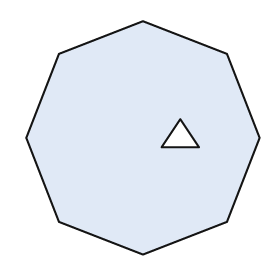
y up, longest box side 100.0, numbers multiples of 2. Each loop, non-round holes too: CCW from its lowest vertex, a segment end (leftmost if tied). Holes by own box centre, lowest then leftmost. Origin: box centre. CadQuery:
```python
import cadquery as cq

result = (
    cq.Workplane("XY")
    .moveTo(0.0, -50.0)
    .lineTo(36.0, -36.0)
    .lineTo(50.0, 0.0)
    .lineTo(36.0, 36.0)
    .lineTo(0.0, 50.0)
    .lineTo(-36.0, 36.0)
    .lineTo(-50.0, 0.0)
    .lineTo(-36.0, -36.0)
    .close()
    .moveTo(8.0, -4.0)
    .lineTo(24.0, -4.0)
    .lineTo(16.0, 8.0)
    .close()
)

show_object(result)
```